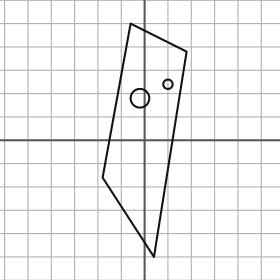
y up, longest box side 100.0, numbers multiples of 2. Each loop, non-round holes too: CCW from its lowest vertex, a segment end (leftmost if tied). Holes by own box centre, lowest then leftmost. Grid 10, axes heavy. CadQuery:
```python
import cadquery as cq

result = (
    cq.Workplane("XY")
    .moveTo(4.0, -50.0)
    .lineTo(18.0, 38.0)
    .lineTo(-6.0, 50.0)
    .lineTo(-18.0, -16.0)
    .close()
    .moveTo(-2.0, 18.0)
    .circle(4.0)
    .moveTo(10.0, 24.0)
    .circle(2.0)
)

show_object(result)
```